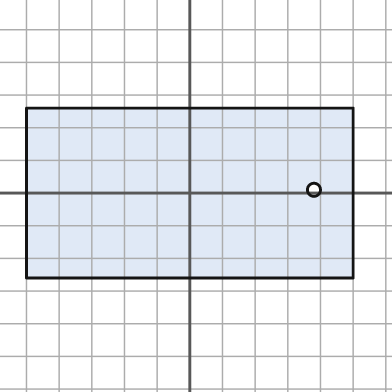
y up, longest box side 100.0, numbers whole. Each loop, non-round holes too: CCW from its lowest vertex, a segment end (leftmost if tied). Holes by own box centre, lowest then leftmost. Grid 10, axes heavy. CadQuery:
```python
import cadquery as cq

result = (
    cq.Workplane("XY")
    .moveTo(-50.0, -26.0)
    .lineTo(50.0, -26.0)
    .lineTo(50.0, 26.0)
    .lineTo(-50.0, 26.0)
    .close()
    .moveTo(38.0, 1.0)
    .circle(2.0)
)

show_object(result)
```